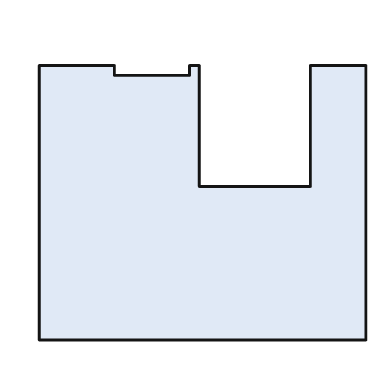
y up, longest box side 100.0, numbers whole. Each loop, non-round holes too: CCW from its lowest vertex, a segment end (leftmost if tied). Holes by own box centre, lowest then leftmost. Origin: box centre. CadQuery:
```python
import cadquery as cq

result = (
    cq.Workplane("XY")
    .moveTo(-50.0, -42.0)
    .lineTo(50.0, -42.0)
    .lineTo(50.0, 42.0)
    .lineTo(33.0, 42.0)
    .lineTo(33.0, 5.0)
    .lineTo(-1.0, 5.0)
    .lineTo(-1.0, 42.0)
    .lineTo(-4.0, 42.0)
    .lineTo(-4.0, 39.0)
    .lineTo(-27.0, 39.0)
    .lineTo(-27.0, 42.0)
    .lineTo(-50.0, 42.0)
    .close()
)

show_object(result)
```